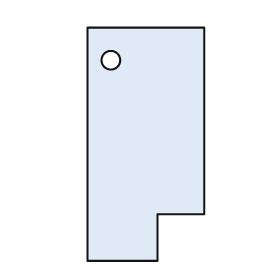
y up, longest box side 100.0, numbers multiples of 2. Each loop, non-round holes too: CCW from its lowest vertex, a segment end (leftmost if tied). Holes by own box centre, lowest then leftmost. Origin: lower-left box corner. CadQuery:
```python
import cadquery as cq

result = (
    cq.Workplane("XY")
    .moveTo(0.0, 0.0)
    .lineTo(30.0, 0.0)
    .lineTo(30.0, 20.0)
    .lineTo(50.0, 20.0)
    .lineTo(50.0, 100.0)
    .lineTo(0.0, 100.0)
    .close()
    .moveTo(10.0, 86.0)
    .circle(4.0)
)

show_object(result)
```